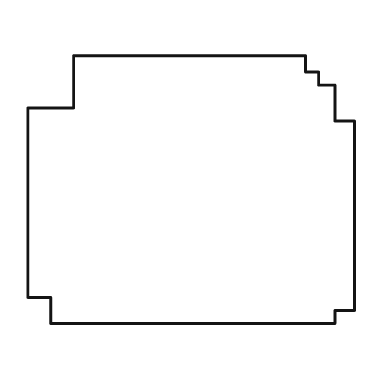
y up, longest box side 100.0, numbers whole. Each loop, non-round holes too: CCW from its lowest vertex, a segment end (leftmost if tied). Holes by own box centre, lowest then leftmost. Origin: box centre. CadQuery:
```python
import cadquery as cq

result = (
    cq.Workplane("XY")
    .moveTo(-43.0, -41.0)
    .lineTo(44.0, -41.0)
    .lineTo(44.0, -37.0)
    .lineTo(50.0, -37.0)
    .lineTo(50.0, 21.0)
    .lineTo(44.0, 21.0)
    .lineTo(44.0, 32.0)
    .lineTo(39.0, 32.0)
    .lineTo(39.0, 36.0)
    .lineTo(35.0, 36.0)
    .lineTo(35.0, 41.0)
    .lineTo(-36.0, 41.0)
    .lineTo(-36.0, 25.0)
    .lineTo(-50.0, 25.0)
    .lineTo(-50.0, -33.0)
    .lineTo(-43.0, -33.0)
    .close()
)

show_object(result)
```